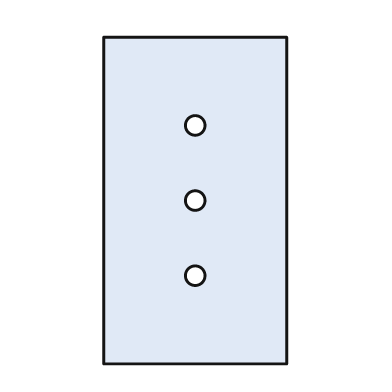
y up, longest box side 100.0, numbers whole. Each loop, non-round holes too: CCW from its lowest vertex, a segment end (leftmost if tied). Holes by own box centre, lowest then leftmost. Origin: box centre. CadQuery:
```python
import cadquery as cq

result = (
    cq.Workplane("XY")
    .moveTo(-28.0, -50.0)
    .lineTo(28.0, -50.0)
    .lineTo(28.0, 50.0)
    .lineTo(-28.0, 50.0)
    .close()
    .moveTo(0.0, -23.0)
    .circle(3.0)
    .moveTo(0.0, 0.0)
    .circle(3.0)
    .moveTo(0.0, 23.0)
    .circle(3.0)
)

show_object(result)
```